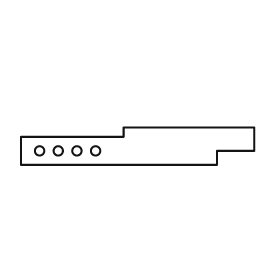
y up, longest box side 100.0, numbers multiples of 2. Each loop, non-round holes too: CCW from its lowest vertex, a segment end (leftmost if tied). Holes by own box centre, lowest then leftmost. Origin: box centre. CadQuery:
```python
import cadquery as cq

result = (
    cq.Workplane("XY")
    .moveTo(-50.0, -8.0)
    .lineTo(34.0, -8.0)
    .lineTo(34.0, -2.0)
    .lineTo(50.0, -2.0)
    .lineTo(50.0, 8.0)
    .lineTo(-6.0, 8.0)
    .lineTo(-6.0, 4.0)
    .lineTo(-50.0, 4.0)
    .close()
    .moveTo(-42.0, -2.0)
    .circle(2.0)
    .moveTo(-34.0, -2.0)
    .circle(2.0)
    .moveTo(-26.0, -2.0)
    .circle(2.0)
    .moveTo(-18.0, -2.0)
    .circle(2.0)
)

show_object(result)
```